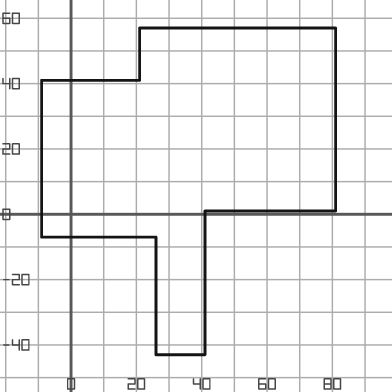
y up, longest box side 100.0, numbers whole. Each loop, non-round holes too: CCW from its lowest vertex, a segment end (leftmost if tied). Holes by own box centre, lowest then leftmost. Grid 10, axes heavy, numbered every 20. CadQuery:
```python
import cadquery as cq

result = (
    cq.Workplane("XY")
    .moveTo(26.0, -43.0)
    .lineTo(41.0, -43.0)
    .lineTo(41.0, 1.0)
    .lineTo(81.0, 1.0)
    .lineTo(81.0, 57.0)
    .lineTo(21.0, 57.0)
    .lineTo(21.0, 41.0)
    .lineTo(-9.0, 41.0)
    .lineTo(-9.0, -7.0)
    .lineTo(26.0, -7.0)
    .close()
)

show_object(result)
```